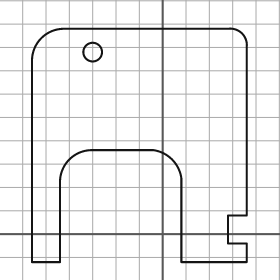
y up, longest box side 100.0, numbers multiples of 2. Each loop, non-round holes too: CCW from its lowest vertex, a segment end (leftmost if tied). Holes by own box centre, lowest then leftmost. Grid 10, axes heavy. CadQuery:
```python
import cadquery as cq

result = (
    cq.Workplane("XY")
    .moveTo(-56.0, -12.0)
    .lineTo(-44.0, -12.0)
    .lineTo(-44.0, 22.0)
    .threePointArc((-40.0, 32.0), (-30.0, 36.0))
    .lineTo(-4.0, 36.0)
    .threePointArc((4.0, 32.0), (8.0, 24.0))
    .lineTo(8.0, -12.0)
    .lineTo(36.0, -12.0)
    .lineTo(36.0, -4.0)
    .lineTo(28.0, -4.0)
    .lineTo(28.0, 8.0)
    .lineTo(36.0, 8.0)
    .lineTo(36.0, 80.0)
    .threePointArc((34.0, 86.0), (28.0, 88.0))
    .lineTo(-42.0, 88.0)
    .threePointArc((-52.0, 84.0), (-56.0, 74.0))
    .close()
    .moveTo(-30.0, 78.0)
    .circle(4.0)
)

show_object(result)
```